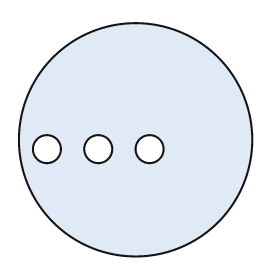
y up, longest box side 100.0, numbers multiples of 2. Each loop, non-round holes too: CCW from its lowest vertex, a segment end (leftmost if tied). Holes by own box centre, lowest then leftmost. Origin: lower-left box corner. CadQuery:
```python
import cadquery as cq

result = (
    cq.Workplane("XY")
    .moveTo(50.0, 50.0)
    .circle(50.0)
    .moveTo(12.0, 46.0)
    .circle(6.0)
    .moveTo(34.0, 46.0)
    .circle(6.0)
    .moveTo(56.0, 46.0)
    .circle(6.0)
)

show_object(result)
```